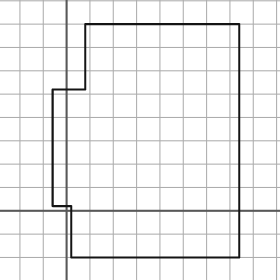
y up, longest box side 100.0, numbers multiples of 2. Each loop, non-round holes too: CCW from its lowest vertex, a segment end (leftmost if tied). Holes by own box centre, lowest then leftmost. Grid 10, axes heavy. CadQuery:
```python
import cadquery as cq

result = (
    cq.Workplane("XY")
    .moveTo(2.0, -20.0)
    .lineTo(74.0, -20.0)
    .lineTo(74.0, 80.0)
    .lineTo(8.0, 80.0)
    .lineTo(8.0, 52.0)
    .lineTo(-6.0, 52.0)
    .lineTo(-6.0, 2.0)
    .lineTo(2.0, 2.0)
    .close()
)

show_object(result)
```